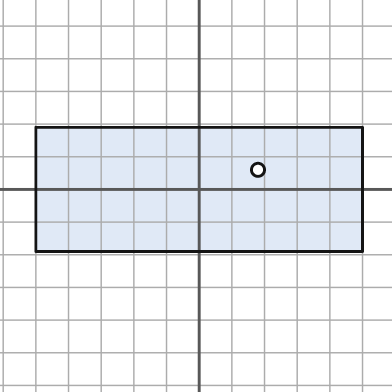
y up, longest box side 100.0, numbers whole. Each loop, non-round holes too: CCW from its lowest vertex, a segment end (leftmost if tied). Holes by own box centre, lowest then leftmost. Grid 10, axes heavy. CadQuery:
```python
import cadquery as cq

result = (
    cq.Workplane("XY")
    .moveTo(-50.0, -19.0)
    .lineTo(50.0, -19.0)
    .lineTo(50.0, 19.0)
    .lineTo(-50.0, 19.0)
    .close()
    .moveTo(18.0, 6.0)
    .circle(2.0)
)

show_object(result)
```